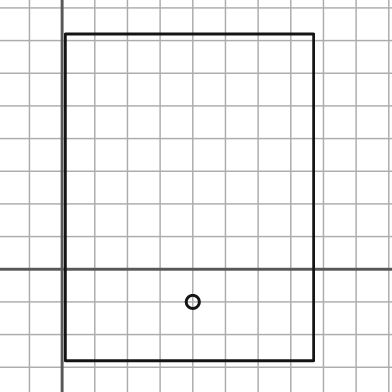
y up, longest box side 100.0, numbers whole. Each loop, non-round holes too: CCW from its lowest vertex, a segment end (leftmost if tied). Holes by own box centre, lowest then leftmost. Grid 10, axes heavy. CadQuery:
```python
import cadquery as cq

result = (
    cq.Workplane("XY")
    .moveTo(1.0, -28.0)
    .lineTo(77.0, -28.0)
    .lineTo(77.0, 72.0)
    .lineTo(1.0, 72.0)
    .close()
    .moveTo(40.0, -10.0)
    .circle(2.0)
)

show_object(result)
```